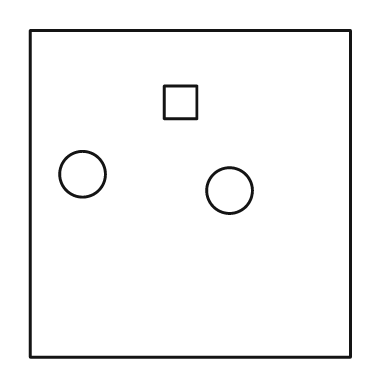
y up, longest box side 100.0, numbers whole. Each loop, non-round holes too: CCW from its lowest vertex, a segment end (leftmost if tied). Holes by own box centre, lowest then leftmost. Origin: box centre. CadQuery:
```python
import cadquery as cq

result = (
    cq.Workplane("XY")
    .moveTo(-49.0, -50.0)
    .lineTo(49.0, -50.0)
    .lineTo(49.0, 50.0)
    .lineTo(-49.0, 50.0)
    .close()
    .moveTo(12.0, 1.0)
    .circle(7.0)
    .moveTo(-33.0, 6.0)
    .circle(7.0)
    .moveTo(-8.0, 23.0)
    .lineTo(2.0, 23.0)
    .lineTo(2.0, 33.0)
    .lineTo(-8.0, 33.0)
    .close()
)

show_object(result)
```